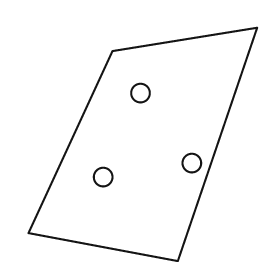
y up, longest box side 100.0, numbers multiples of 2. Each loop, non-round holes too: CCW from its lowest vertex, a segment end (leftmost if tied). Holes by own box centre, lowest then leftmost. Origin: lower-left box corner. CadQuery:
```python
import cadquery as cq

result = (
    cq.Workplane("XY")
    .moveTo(64.0, 0.0)
    .lineTo(98.0, 100.0)
    .lineTo(36.0, 90.0)
    .lineTo(0.0, 12.0)
    .close()
    .moveTo(32.0, 36.0)
    .circle(4.0)
    .moveTo(70.0, 42.0)
    .circle(4.0)
    .moveTo(48.0, 72.0)
    .circle(4.0)
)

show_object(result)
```